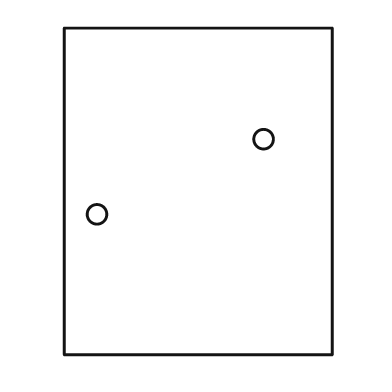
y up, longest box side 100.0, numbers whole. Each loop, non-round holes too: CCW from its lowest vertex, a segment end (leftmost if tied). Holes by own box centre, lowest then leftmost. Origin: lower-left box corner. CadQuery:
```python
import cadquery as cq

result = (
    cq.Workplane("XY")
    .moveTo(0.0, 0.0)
    .lineTo(82.0, 0.0)
    .lineTo(82.0, 100.0)
    .lineTo(0.0, 100.0)
    .close()
    .moveTo(10.0, 43.0)
    .circle(3.0)
    .moveTo(61.0, 66.0)
    .circle(3.0)
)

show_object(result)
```